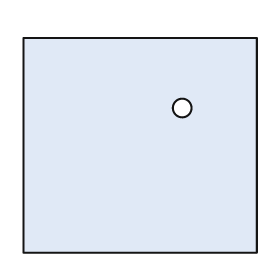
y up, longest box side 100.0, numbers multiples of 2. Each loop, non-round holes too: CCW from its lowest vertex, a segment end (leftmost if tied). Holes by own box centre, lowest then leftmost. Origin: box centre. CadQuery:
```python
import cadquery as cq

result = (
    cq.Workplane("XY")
    .moveTo(-50.0, -46.0)
    .lineTo(50.0, -46.0)
    .lineTo(50.0, 46.0)
    .lineTo(-50.0, 46.0)
    .close()
    .moveTo(18.0, 16.0)
    .circle(4.0)
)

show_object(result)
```